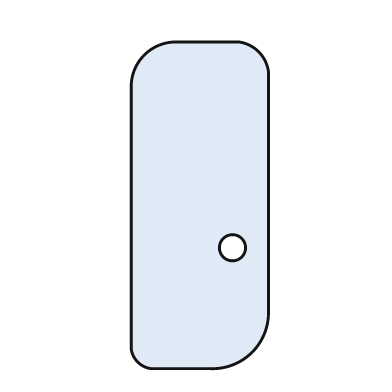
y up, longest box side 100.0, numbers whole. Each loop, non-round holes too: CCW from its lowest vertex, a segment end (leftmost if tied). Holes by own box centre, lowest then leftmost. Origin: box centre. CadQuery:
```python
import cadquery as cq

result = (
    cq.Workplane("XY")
    .moveTo(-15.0, -50.0)
    .lineTo(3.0, -50.0)
    .threePointArc((16.0, -45.0), (21.0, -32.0))
    .lineTo(21.0, 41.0)
    .threePointArc((18.0, 47.0), (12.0, 50.0))
    .lineTo(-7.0, 50.0)
    .threePointArc((-17.0, 46.0), (-21.0, 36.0))
    .lineTo(-21.0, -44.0)
    .threePointArc((-19.0, -48.0), (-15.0, -50.0))
    .close()
    .moveTo(10.0, -13.0)
    .circle(4.0)
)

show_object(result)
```